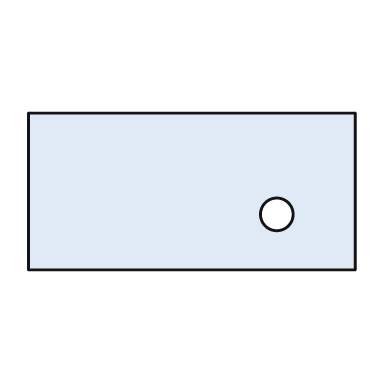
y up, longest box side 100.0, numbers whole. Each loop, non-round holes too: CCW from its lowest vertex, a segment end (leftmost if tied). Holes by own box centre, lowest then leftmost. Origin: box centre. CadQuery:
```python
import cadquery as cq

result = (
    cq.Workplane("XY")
    .moveTo(-50.0, -24.0)
    .lineTo(50.0, -24.0)
    .lineTo(50.0, 24.0)
    .lineTo(-50.0, 24.0)
    .close()
    .moveTo(26.0, -7.0)
    .circle(5.0)
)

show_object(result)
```